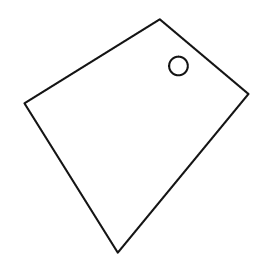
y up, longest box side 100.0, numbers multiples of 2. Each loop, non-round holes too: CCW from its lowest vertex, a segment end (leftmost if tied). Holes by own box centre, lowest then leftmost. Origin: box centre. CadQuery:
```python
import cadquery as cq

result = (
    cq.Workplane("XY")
    .moveTo(-8.0, -50.0)
    .lineTo(48.0, 18.0)
    .lineTo(10.0, 50.0)
    .lineTo(-48.0, 14.0)
    .close()
    .moveTo(18.0, 30.0)
    .circle(4.0)
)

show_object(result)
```